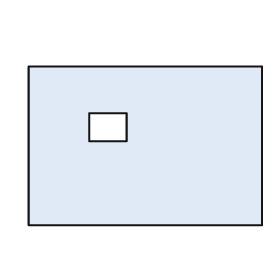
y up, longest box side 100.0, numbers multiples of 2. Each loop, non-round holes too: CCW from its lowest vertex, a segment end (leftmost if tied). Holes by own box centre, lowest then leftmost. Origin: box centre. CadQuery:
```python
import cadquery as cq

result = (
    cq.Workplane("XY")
    .moveTo(-50.0, -34.0)
    .lineTo(50.0, -34.0)
    .lineTo(50.0, 34.0)
    .lineTo(-50.0, 34.0)
    .close()
    .moveTo(-24.0, 2.0)
    .lineTo(-8.0, 2.0)
    .lineTo(-8.0, 14.0)
    .lineTo(-24.0, 14.0)
    .close()
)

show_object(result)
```